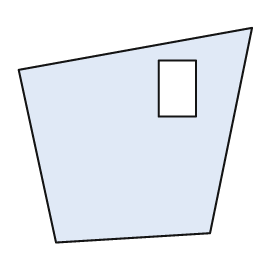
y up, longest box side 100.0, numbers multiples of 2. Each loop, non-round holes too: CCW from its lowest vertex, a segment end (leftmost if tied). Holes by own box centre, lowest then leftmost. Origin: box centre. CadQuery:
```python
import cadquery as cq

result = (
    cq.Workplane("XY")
    .moveTo(-34.0, -46.0)
    .lineTo(32.0, -42.0)
    .lineTo(50.0, 46.0)
    .lineTo(-50.0, 28.0)
    .close()
    .moveTo(10.0, 8.0)
    .lineTo(26.0, 8.0)
    .lineTo(26.0, 32.0)
    .lineTo(10.0, 32.0)
    .close()
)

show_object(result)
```